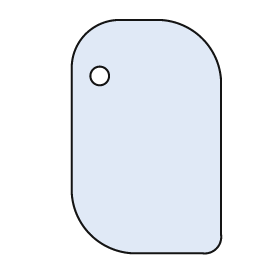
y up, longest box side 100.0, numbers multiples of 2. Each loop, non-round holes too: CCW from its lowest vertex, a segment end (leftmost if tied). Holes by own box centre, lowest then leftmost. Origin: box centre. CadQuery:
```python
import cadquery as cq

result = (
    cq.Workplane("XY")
    .moveTo(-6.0, -50.0)
    .lineTo(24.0, -50.0)
    .threePointArc((30.0, -48.0), (32.0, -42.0))
    .lineTo(32.0, 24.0)
    .threePointArc((24.0, 42.0), (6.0, 50.0))
    .lineTo(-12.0, 50.0)
    .threePointArc((-26.0, 44.0), (-32.0, 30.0))
    .lineTo(-32.0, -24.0)
    .threePointArc((-24.0, -42.0), (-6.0, -50.0))
    .close()
    .moveTo(-20.0, 26.0)
    .circle(4.0)
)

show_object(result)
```